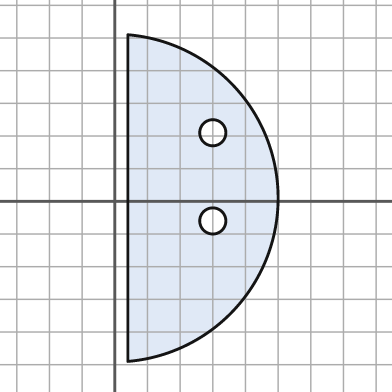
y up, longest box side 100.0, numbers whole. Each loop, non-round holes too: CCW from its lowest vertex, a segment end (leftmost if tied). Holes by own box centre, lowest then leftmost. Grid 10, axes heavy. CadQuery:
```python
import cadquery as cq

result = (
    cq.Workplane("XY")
    .moveTo(4.0, -49.0)
    .threePointArc((50.0, 1.0), (4.0, 51.0))
    .close()
    .moveTo(30.0, -6.0)
    .circle(4.0)
    .moveTo(30.0, 21.0)
    .circle(4.0)
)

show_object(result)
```